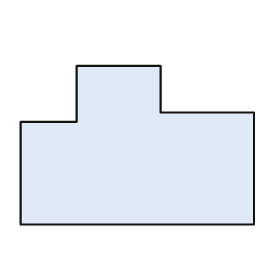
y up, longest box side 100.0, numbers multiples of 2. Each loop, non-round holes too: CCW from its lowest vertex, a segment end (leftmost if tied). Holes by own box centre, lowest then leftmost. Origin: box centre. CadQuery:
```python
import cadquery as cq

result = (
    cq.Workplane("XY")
    .moveTo(-50.0, -34.0)
    .lineTo(50.0, -34.0)
    .lineTo(50.0, 14.0)
    .lineTo(10.0, 14.0)
    .lineTo(10.0, 34.0)
    .lineTo(-26.0, 34.0)
    .lineTo(-26.0, 10.0)
    .lineTo(-50.0, 10.0)
    .close()
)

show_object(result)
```